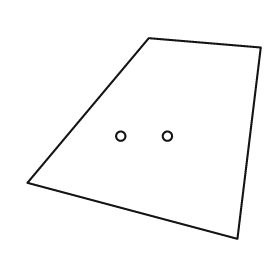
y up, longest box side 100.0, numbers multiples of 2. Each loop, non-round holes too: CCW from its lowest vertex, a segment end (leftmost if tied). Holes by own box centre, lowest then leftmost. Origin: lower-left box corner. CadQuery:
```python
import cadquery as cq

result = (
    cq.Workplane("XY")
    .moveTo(90.0, 0.0)
    .lineTo(100.0, 82.0)
    .lineTo(52.0, 86.0)
    .lineTo(0.0, 24.0)
    .close()
    .moveTo(40.0, 44.0)
    .circle(2.0)
    .moveTo(60.0, 44.0)
    .circle(2.0)
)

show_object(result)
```